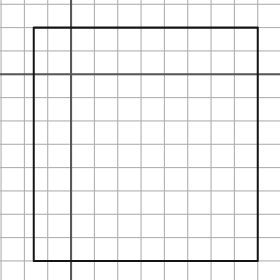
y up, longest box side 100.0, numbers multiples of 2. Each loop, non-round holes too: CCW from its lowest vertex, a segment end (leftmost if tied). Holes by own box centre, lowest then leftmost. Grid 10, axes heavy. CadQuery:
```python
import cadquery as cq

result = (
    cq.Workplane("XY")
    .moveTo(-16.0, -80.0)
    .lineTo(80.0, -80.0)
    .lineTo(80.0, 20.0)
    .lineTo(-16.0, 20.0)
    .close()
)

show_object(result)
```